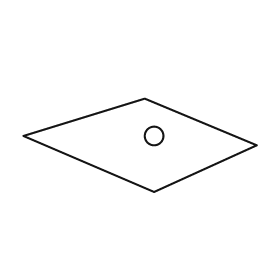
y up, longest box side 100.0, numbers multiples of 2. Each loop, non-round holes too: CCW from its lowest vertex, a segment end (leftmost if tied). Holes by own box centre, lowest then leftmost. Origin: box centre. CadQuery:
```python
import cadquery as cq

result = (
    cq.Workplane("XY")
    .moveTo(6.0, -20.0)
    .lineTo(50.0, 0.0)
    .lineTo(2.0, 20.0)
    .lineTo(-50.0, 4.0)
    .close()
    .moveTo(6.0, 4.0)
    .circle(4.0)
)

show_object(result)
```